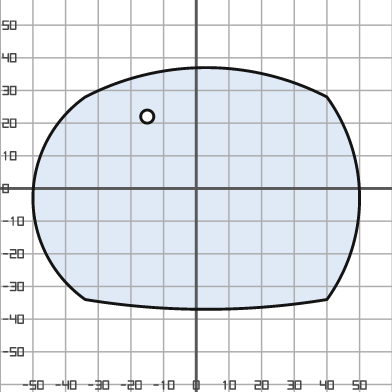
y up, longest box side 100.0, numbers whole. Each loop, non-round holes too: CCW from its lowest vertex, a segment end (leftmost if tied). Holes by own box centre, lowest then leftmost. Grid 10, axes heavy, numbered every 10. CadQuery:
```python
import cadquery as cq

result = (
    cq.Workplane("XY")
    .moveTo(-34.0, -34.0)
    .threePointArc((3.0, -37.0), (40.0, -34.0))
    .threePointArc((50.0, -3.0), (40.0, 28.0))
    .threePointArc((3.0, 37.0), (-34.0, 28.0))
    .threePointArc((-50.0, -3.0), (-34.0, -34.0))
    .close()
    .moveTo(-15.0, 22.0)
    .circle(2.0)
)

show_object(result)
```